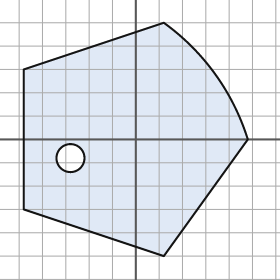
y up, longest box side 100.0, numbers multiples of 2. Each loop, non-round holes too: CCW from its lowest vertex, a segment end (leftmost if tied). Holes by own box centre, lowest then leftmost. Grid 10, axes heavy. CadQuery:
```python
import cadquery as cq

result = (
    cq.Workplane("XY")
    .moveTo(12.0, -50.0)
    .lineTo(48.0, 0.0)
    .threePointArc((34.0, 28.0), (12.0, 50.0))
    .lineTo(-48.0, 30.0)
    .lineTo(-48.0, -30.0)
    .close()
    .moveTo(-28.0, -8.0)
    .circle(6.0)
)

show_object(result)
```